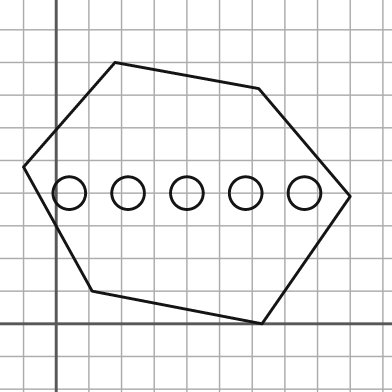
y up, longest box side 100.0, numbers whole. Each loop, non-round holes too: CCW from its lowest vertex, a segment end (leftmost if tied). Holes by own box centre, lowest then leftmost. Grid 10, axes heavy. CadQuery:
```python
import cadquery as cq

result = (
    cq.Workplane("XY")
    .moveTo(63.0, 0.0)
    .lineTo(90.0, 39.0)
    .lineTo(62.0, 72.0)
    .lineTo(18.0, 80.0)
    .lineTo(-10.0, 48.0)
    .lineTo(11.0, 10.0)
    .close()
    .moveTo(4.0, 40.0)
    .circle(5.0)
    .moveTo(22.0, 40.0)
    .circle(5.0)
    .moveTo(40.0, 40.0)
    .circle(5.0)
    .moveTo(58.0, 40.0)
    .circle(5.0)
    .moveTo(76.0, 40.0)
    .circle(5.0)
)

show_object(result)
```